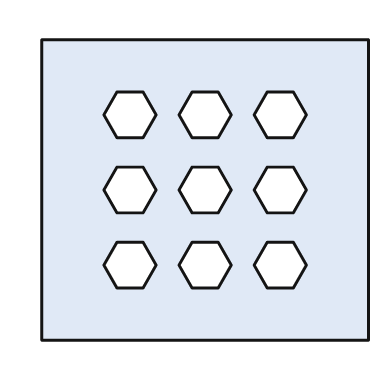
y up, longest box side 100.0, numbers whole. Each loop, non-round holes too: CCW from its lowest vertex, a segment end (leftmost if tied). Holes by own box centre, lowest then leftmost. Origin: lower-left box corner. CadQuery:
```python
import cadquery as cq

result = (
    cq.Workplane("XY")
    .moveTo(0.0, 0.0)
    .lineTo(100.0, 0.0)
    .lineTo(100.0, 92.0)
    .lineTo(0.0, 92.0)
    .close()
    .moveTo(23.0, 16.0)
    .lineTo(31.0, 16.0)
    .lineTo(35.0, 23.0)
    .lineTo(31.0, 30.0)
    .lineTo(23.0, 30.0)
    .lineTo(19.0, 23.0)
    .close()
    .moveTo(46.0, 16.0)
    .lineTo(54.0, 16.0)
    .lineTo(58.0, 23.0)
    .lineTo(54.0, 30.0)
    .lineTo(46.0, 30.0)
    .lineTo(42.0, 23.0)
    .close()
    .moveTo(69.0, 16.0)
    .lineTo(77.0, 16.0)
    .lineTo(81.0, 23.0)
    .lineTo(77.0, 30.0)
    .lineTo(69.0, 30.0)
    .lineTo(65.0, 23.0)
    .close()
    .moveTo(23.0, 39.0)
    .lineTo(31.0, 39.0)
    .lineTo(35.0, 46.0)
    .lineTo(31.0, 53.0)
    .lineTo(23.0, 53.0)
    .lineTo(19.0, 46.0)
    .close()
    .moveTo(46.0, 39.0)
    .lineTo(54.0, 39.0)
    .lineTo(58.0, 46.0)
    .lineTo(54.0, 53.0)
    .lineTo(46.0, 53.0)
    .lineTo(42.0, 46.0)
    .close()
    .moveTo(69.0, 39.0)
    .lineTo(77.0, 39.0)
    .lineTo(81.0, 46.0)
    .lineTo(77.0, 53.0)
    .lineTo(69.0, 53.0)
    .lineTo(65.0, 46.0)
    .close()
    .moveTo(23.0, 62.0)
    .lineTo(31.0, 62.0)
    .lineTo(35.0, 69.0)
    .lineTo(31.0, 76.0)
    .lineTo(23.0, 76.0)
    .lineTo(19.0, 69.0)
    .close()
    .moveTo(46.0, 62.0)
    .lineTo(54.0, 62.0)
    .lineTo(58.0, 69.0)
    .lineTo(54.0, 76.0)
    .lineTo(46.0, 76.0)
    .lineTo(42.0, 69.0)
    .close()
    .moveTo(69.0, 62.0)
    .lineTo(77.0, 62.0)
    .lineTo(81.0, 69.0)
    .lineTo(77.0, 76.0)
    .lineTo(69.0, 76.0)
    .lineTo(65.0, 69.0)
    .close()
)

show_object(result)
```